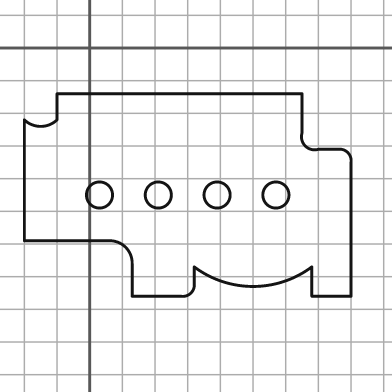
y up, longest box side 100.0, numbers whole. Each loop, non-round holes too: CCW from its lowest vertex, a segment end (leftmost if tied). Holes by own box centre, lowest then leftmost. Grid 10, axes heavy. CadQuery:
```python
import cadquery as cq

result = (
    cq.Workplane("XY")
    .moveTo(13.0, -76.0)
    .lineTo(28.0, -76.0)
    .threePointArc((31.0, -75.0), (32.0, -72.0))
    .lineTo(32.0, -67.0)
    .threePointArc((50.0, -73.0), (68.0, -67.0))
    .lineTo(68.0, -76.0)
    .lineTo(80.0, -76.0)
    .lineTo(80.0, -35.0)
    .threePointArc((79.0, -32.0), (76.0, -31.0))
    .lineTo(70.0, -31.0)
    .threePointArc((66.0, -30.0), (65.0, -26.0))
    .lineTo(65.0, -14.0)
    .lineTo(-10.0, -14.0)
    .lineTo(-10.0, -22.0)
    .threePointArc((-15.0, -24.0), (-20.0, -22.0))
    .lineTo(-20.0, -59.0)
    .lineTo(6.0, -59.0)
    .threePointArc((11.0, -61.0), (13.0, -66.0))
    .close()
    .moveTo(3.0, -45.0)
    .circle(4.0)
    .moveTo(21.0, -45.0)
    .circle(4.0)
    .moveTo(39.0, -45.0)
    .circle(4.0)
    .moveTo(57.0, -45.0)
    .circle(4.0)
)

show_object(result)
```